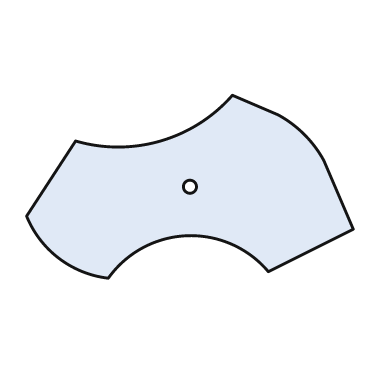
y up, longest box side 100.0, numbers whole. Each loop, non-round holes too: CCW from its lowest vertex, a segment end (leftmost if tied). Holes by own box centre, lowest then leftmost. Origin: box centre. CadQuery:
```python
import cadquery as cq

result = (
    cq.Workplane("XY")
    .moveTo(-25.0, -28.0)
    .threePointArc((-1.0, -15.0), (24.0, -26.0))
    .lineTo(50.0, -13.0)
    .lineTo(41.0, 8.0)
    .threePointArc((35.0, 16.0), (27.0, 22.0))
    .lineTo(13.0, 28.0)
    .threePointArc((-9.0, 14.0), (-35.0, 14.0))
    .lineTo(-50.0, -9.0)
    .threePointArc((-40.0, -22.0), (-25.0, -28.0))
    .close()
    .moveTo(0.0, 0.0)
    .circle(2.0)
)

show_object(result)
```